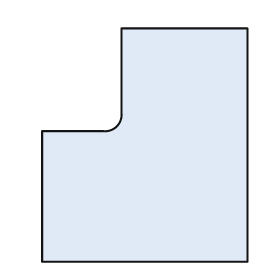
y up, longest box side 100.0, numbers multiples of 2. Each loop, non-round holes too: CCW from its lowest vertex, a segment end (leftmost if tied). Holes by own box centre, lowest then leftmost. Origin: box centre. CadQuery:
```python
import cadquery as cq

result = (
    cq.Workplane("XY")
    .moveTo(-44.0, -50.0)
    .lineTo(44.0, -50.0)
    .lineTo(44.0, 50.0)
    .lineTo(-10.0, 50.0)
    .lineTo(-10.0, 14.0)
    .threePointArc((-12.0, 8.0), (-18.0, 6.0))
    .lineTo(-44.0, 6.0)
    .close()
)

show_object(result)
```